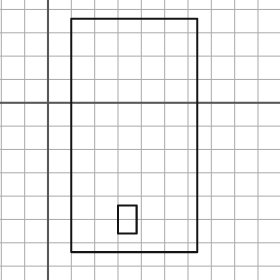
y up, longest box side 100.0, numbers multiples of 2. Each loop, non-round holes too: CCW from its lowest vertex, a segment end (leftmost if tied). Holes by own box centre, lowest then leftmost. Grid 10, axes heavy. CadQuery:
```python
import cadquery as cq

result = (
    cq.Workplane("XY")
    .moveTo(10.0, -64.0)
    .lineTo(64.0, -64.0)
    .lineTo(64.0, 36.0)
    .lineTo(10.0, 36.0)
    .close()
    .moveTo(30.0, -56.0)
    .lineTo(38.0, -56.0)
    .lineTo(38.0, -44.0)
    .lineTo(30.0, -44.0)
    .close()
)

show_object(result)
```